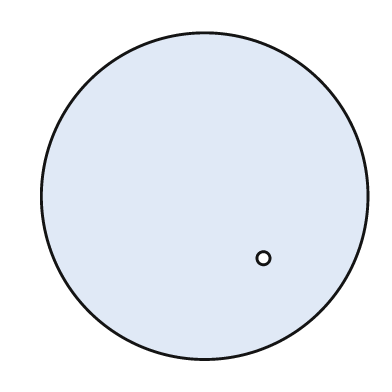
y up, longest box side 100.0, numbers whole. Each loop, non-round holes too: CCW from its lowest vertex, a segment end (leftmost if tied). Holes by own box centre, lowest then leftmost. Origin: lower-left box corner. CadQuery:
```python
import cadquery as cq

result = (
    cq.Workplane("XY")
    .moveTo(50.0, 50.0)
    .circle(50.0)
    .moveTo(68.0, 31.0)
    .circle(2.0)
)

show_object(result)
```